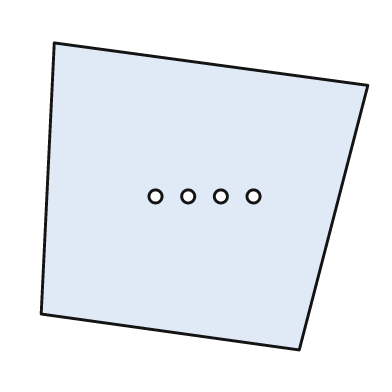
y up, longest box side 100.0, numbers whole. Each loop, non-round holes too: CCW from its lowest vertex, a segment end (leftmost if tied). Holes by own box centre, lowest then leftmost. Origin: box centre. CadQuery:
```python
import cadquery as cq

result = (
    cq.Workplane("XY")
    .moveTo(29.0, -47.0)
    .lineTo(50.0, 34.0)
    .lineTo(-46.0, 47.0)
    .lineTo(-50.0, -36.0)
    .close()
    .moveTo(-15.0, 0.0)
    .circle(2.0)
    .moveTo(-5.0, 0.0)
    .circle(2.0)
    .moveTo(5.0, 0.0)
    .circle(2.0)
    .moveTo(15.0, 0.0)
    .circle(2.0)
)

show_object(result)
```